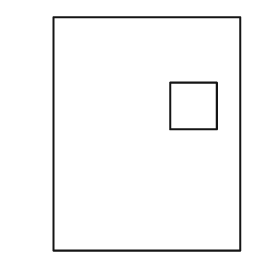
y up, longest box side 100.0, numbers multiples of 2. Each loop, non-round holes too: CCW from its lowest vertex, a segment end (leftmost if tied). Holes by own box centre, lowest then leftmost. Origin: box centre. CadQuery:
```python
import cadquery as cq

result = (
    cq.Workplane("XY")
    .moveTo(-40.0, -50.0)
    .lineTo(40.0, -50.0)
    .lineTo(40.0, 50.0)
    .lineTo(-40.0, 50.0)
    .close()
    .moveTo(10.0, 2.0)
    .lineTo(30.0, 2.0)
    .lineTo(30.0, 22.0)
    .lineTo(10.0, 22.0)
    .close()
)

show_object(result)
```